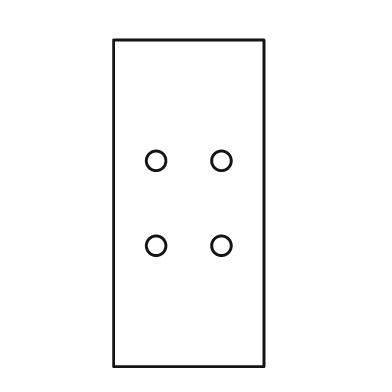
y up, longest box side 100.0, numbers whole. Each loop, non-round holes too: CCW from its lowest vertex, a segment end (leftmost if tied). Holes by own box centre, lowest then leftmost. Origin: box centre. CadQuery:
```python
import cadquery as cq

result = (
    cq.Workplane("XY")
    .moveTo(-23.0, -50.0)
    .lineTo(23.0, -50.0)
    .lineTo(23.0, 50.0)
    .lineTo(-23.0, 50.0)
    .close()
    .moveTo(-10.0, -13.0)
    .circle(3.0)
    .moveTo(10.0, -13.0)
    .circle(3.0)
    .moveTo(-10.0, 13.0)
    .circle(3.0)
    .moveTo(10.0, 13.0)
    .circle(3.0)
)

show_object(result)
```